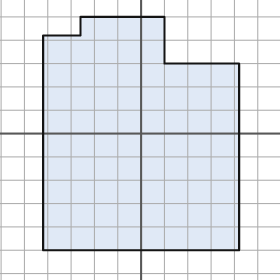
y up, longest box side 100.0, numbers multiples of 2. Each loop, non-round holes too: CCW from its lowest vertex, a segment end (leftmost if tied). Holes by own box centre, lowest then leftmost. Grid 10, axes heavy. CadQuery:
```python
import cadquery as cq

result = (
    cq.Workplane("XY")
    .moveTo(-42.0, -50.0)
    .lineTo(42.0, -50.0)
    .lineTo(42.0, 30.0)
    .lineTo(10.0, 30.0)
    .lineTo(10.0, 50.0)
    .lineTo(-26.0, 50.0)
    .lineTo(-26.0, 42.0)
    .lineTo(-42.0, 42.0)
    .close()
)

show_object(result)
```